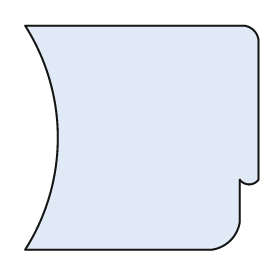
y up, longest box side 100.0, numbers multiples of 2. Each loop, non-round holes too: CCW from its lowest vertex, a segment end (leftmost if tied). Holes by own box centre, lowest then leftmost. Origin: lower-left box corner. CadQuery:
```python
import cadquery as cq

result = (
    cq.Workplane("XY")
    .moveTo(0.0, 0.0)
    .lineTo(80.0, 0.0)
    .threePointArc((88.0, 4.0), (92.0, 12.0))
    .lineTo(92.0, 30.0)
    .threePointArc((96.0, 28.0), (100.0, 30.0))
    .lineTo(100.0, 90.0)
    .threePointArc((98.0, 94.0), (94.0, 96.0))
    .lineTo(0.0, 96.0)
    .threePointArc((14.0, 48.0), (0.0, 0.0))
    .close()
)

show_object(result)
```